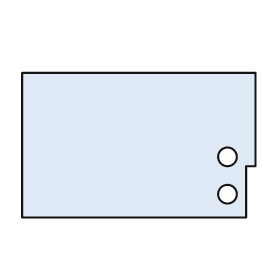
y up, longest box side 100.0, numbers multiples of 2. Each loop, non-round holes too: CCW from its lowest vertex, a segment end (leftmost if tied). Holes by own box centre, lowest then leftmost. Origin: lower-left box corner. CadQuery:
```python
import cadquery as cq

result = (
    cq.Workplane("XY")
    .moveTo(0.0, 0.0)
    .lineTo(96.0, 0.0)
    .lineTo(96.0, 22.0)
    .lineTo(100.0, 22.0)
    .lineTo(100.0, 62.0)
    .lineTo(0.0, 62.0)
    .close()
    .moveTo(88.0, 10.0)
    .circle(4.0)
    .moveTo(88.0, 26.0)
    .circle(4.0)
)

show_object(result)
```